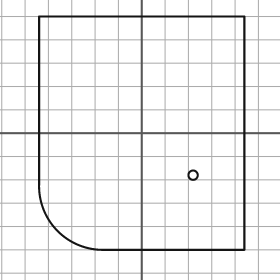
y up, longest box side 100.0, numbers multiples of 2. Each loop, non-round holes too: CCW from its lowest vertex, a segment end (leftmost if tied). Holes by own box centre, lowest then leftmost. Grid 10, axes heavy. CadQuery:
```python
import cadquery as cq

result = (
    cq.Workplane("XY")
    .moveTo(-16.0, -50.0)
    .lineTo(44.0, -50.0)
    .lineTo(44.0, 50.0)
    .lineTo(-44.0, 50.0)
    .lineTo(-44.0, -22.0)
    .threePointArc((-36.0, -42.0), (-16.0, -50.0))
    .close()
    .moveTo(22.0, -18.0)
    .circle(2.0)
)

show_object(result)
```